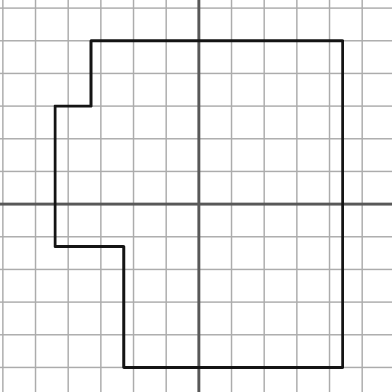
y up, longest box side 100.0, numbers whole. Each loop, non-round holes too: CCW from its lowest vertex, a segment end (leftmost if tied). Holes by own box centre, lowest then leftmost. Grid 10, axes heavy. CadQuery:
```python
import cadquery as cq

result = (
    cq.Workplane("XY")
    .moveTo(-23.0, -50.0)
    .lineTo(44.0, -50.0)
    .lineTo(44.0, 50.0)
    .lineTo(-33.0, 50.0)
    .lineTo(-33.0, 30.0)
    .lineTo(-44.0, 30.0)
    .lineTo(-44.0, -13.0)
    .lineTo(-23.0, -13.0)
    .close()
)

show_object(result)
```